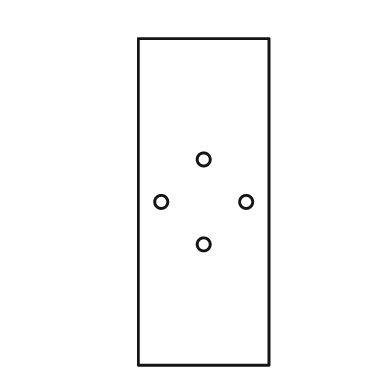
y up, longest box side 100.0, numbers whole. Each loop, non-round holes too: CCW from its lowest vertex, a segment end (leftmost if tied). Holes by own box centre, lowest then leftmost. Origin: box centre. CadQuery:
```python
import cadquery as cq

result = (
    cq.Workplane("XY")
    .moveTo(-20.0, -50.0)
    .lineTo(20.0, -50.0)
    .lineTo(20.0, 50.0)
    .lineTo(-20.0, 50.0)
    .close()
    .moveTo(0.0, -13.0)
    .circle(2.0)
    .moveTo(-13.0, 0.0)
    .circle(2.0)
    .moveTo(13.0, 0.0)
    .circle(2.0)
    .moveTo(0.0, 13.0)
    .circle(2.0)
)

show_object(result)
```